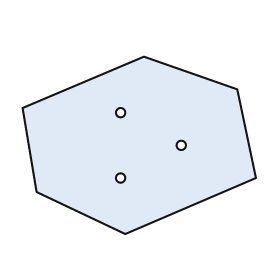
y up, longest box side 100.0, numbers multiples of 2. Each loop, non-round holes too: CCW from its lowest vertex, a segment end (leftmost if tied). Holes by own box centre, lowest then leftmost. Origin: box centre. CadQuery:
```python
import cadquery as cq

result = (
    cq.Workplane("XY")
    .moveTo(-6.0, -38.0)
    .lineTo(50.0, -14.0)
    .lineTo(42.0, 24.0)
    .lineTo(2.0, 38.0)
    .lineTo(-50.0, 16.0)
    .lineTo(-44.0, -20.0)
    .close()
    .moveTo(-8.0, -14.0)
    .circle(2.0)
    .moveTo(18.0, 0.0)
    .circle(2.0)
    .moveTo(-8.0, 14.0)
    .circle(2.0)
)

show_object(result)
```